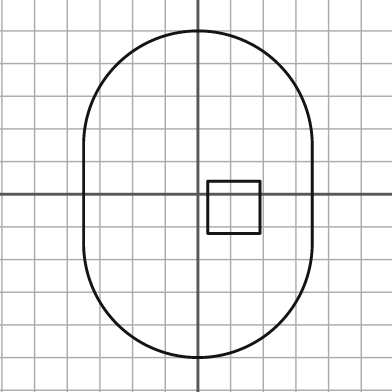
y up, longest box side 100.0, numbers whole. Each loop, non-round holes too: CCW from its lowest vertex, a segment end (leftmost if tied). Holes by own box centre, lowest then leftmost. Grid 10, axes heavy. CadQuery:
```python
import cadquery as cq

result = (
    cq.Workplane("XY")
    .moveTo(-35.0, -15.0)
    .threePointArc((0.0, -50.0), (35.0, -15.0))
    .lineTo(35.0, 15.0)
    .threePointArc((0.0, 50.0), (-35.0, 15.0))
    .close()
    .moveTo(3.0, -12.0)
    .lineTo(19.0, -12.0)
    .lineTo(19.0, 4.0)
    .lineTo(3.0, 4.0)
    .close()
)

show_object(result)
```